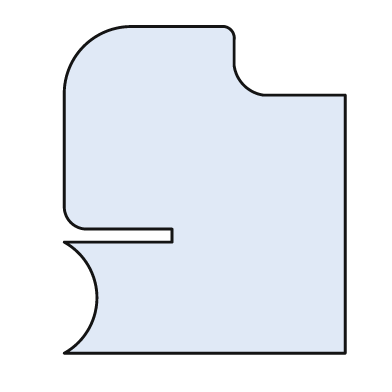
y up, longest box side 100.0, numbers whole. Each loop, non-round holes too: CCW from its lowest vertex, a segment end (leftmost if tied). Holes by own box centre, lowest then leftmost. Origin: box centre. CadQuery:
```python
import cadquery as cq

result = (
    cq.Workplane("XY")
    .moveTo(-43.0, -50.0)
    .lineTo(43.0, -50.0)
    .lineTo(43.0, 29.0)
    .lineTo(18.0, 29.0)
    .threePointArc((12.0, 32.0), (9.0, 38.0))
    .lineTo(9.0, 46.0)
    .threePointArc((8.0, 49.0), (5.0, 50.0))
    .lineTo(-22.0, 50.0)
    .threePointArc((-37.0, 44.0), (-43.0, 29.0))
    .lineTo(-43.0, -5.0)
    .threePointArc((-41.0, -10.0), (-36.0, -12.0))
    .lineTo(-10.0, -12.0)
    .lineTo(-10.0, -16.0)
    .lineTo(-43.0, -16.0)
    .threePointArc((-33.0, -33.0), (-43.0, -50.0))
    .close()
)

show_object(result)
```